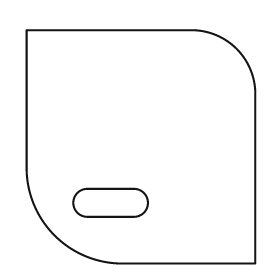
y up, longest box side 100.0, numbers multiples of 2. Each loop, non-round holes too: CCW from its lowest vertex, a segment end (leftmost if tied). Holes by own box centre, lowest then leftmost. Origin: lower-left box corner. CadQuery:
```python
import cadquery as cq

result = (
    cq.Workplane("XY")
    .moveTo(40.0, 0.0)
    .lineTo(98.0, 0.0)
    .lineTo(98.0, 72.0)
    .threePointArc((90.0, 92.0), (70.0, 100.0))
    .lineTo(0.0, 100.0)
    .lineTo(0.0, 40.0)
    .threePointArc((12.0, 12.0), (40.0, 0.0))
    .close()
    .moveTo(26.0, 20.0)
    .lineTo(46.0, 20.0)
    .threePointArc((52.0, 26.0), (46.0, 32.0))
    .lineTo(26.0, 32.0)
    .threePointArc((20.0, 26.0), (26.0, 20.0))
    .close()
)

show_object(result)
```